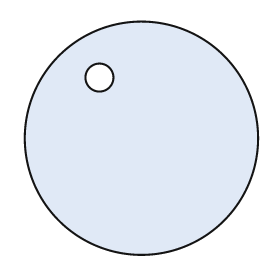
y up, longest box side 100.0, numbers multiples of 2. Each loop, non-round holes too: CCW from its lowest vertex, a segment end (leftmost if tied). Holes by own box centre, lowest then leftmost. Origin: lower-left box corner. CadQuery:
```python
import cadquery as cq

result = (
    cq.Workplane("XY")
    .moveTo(50.0, 50.0)
    .circle(50.0)
    .moveTo(32.0, 76.0)
    .circle(6.0)
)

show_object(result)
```